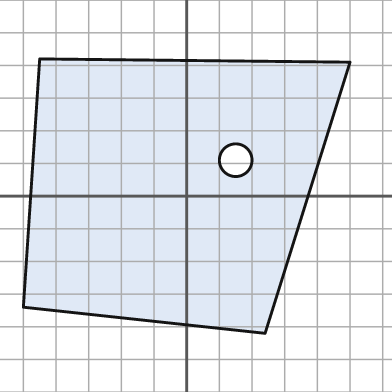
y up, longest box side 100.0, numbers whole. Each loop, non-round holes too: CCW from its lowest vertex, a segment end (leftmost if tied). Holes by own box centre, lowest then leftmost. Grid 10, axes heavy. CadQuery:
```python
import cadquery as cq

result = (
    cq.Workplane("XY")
    .moveTo(24.0, -42.0)
    .lineTo(50.0, 41.0)
    .lineTo(-45.0, 42.0)
    .lineTo(-50.0, -34.0)
    .close()
    .moveTo(15.0, 11.0)
    .circle(5.0)
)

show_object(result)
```